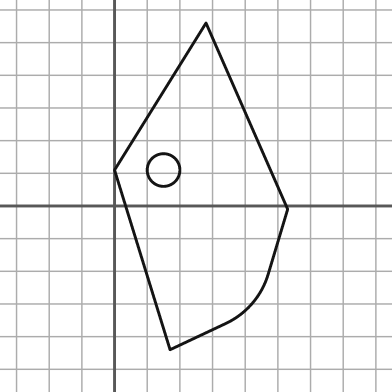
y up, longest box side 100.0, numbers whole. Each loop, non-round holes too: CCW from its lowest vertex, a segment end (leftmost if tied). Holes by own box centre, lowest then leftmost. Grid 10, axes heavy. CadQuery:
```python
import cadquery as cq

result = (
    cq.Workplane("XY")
    .moveTo(17.0, -44.0)
    .lineTo(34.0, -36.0)
    .threePointArc((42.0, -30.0), (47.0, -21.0))
    .lineTo(53.0, -1.0)
    .lineTo(28.0, 56.0)
    .lineTo(0.0, 11.0)
    .close()
    .moveTo(15.0, 11.0)
    .circle(5.0)
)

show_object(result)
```